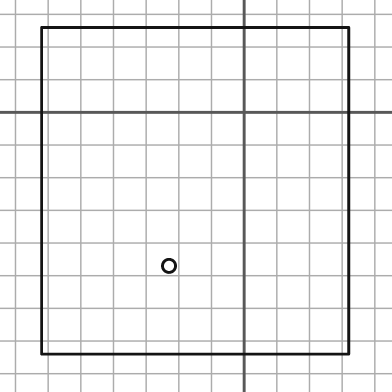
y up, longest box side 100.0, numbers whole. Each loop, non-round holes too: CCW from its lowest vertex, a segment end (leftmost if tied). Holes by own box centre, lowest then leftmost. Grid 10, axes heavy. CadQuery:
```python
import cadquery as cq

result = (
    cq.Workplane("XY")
    .moveTo(-62.0, -74.0)
    .lineTo(32.0, -74.0)
    .lineTo(32.0, 26.0)
    .lineTo(-62.0, 26.0)
    .close()
    .moveTo(-23.0, -47.0)
    .circle(2.0)
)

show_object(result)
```